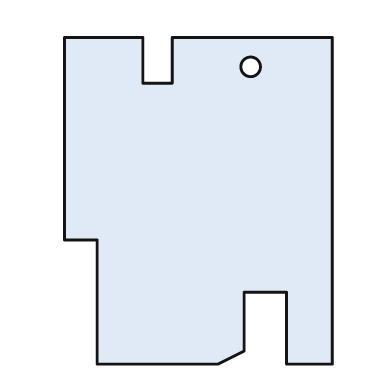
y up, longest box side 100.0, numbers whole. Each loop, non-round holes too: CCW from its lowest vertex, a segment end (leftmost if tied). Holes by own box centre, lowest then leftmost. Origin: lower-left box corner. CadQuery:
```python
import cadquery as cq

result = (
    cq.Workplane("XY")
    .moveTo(10.0, 0.0)
    .lineTo(47.0, 0.0)
    .lineTo(55.0, 4.0)
    .lineTo(55.0, 22.0)
    .lineTo(68.0, 22.0)
    .lineTo(68.0, 0.0)
    .lineTo(82.0, 0.0)
    .lineTo(82.0, 100.0)
    .lineTo(33.0, 100.0)
    .lineTo(33.0, 86.0)
    .lineTo(24.0, 86.0)
    .lineTo(24.0, 100.0)
    .lineTo(0.0, 100.0)
    .lineTo(0.0, 38.0)
    .lineTo(10.0, 38.0)
    .close()
    .moveTo(57.0, 91.0)
    .circle(3.0)
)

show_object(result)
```